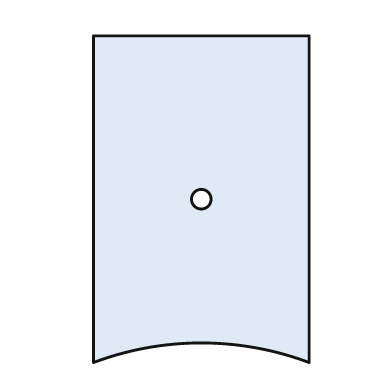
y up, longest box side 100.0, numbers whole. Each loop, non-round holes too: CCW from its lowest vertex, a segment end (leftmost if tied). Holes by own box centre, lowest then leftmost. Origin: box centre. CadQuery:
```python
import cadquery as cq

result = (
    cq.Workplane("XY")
    .moveTo(-33.0, -50.0)
    .threePointArc((0.0, -44.0), (33.0, -50.0))
    .lineTo(33.0, 50.0)
    .lineTo(-33.0, 50.0)
    .close()
    .moveTo(0.0, 0.0)
    .circle(3.0)
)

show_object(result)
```